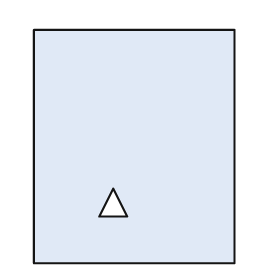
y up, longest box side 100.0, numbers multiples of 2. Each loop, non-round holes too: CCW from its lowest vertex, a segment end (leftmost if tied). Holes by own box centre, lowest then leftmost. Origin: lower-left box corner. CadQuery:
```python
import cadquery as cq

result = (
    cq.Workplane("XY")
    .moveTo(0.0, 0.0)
    .lineTo(86.0, 0.0)
    .lineTo(86.0, 100.0)
    .lineTo(0.0, 100.0)
    .close()
    .moveTo(28.0, 20.0)
    .lineTo(40.0, 20.0)
    .lineTo(34.0, 32.0)
    .close()
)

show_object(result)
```